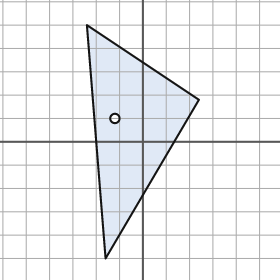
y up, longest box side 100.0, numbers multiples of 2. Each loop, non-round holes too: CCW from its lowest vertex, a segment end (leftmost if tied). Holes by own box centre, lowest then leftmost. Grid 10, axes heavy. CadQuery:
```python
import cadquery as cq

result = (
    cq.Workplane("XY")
    .moveTo(-16.0, -50.0)
    .lineTo(24.0, 18.0)
    .lineTo(-24.0, 50.0)
    .close()
    .moveTo(-12.0, 10.0)
    .circle(2.0)
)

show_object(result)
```